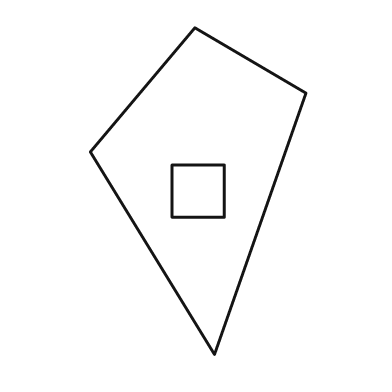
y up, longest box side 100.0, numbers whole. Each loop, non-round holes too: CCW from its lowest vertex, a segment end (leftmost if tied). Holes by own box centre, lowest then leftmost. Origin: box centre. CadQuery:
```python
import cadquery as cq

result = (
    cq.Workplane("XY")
    .moveTo(5.0, -50.0)
    .lineTo(33.0, 30.0)
    .lineTo(-1.0, 50.0)
    .lineTo(-33.0, 12.0)
    .close()
    .moveTo(-8.0, -8.0)
    .lineTo(8.0, -8.0)
    .lineTo(8.0, 8.0)
    .lineTo(-8.0, 8.0)
    .close()
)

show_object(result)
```